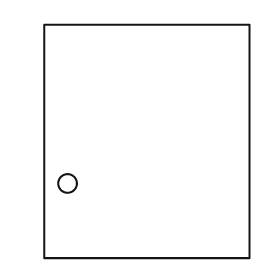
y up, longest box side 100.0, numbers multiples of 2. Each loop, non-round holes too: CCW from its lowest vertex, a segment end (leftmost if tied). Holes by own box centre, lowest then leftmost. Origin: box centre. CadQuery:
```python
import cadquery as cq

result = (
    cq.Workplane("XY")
    .moveTo(-44.0, -50.0)
    .lineTo(44.0, -50.0)
    .lineTo(44.0, 50.0)
    .lineTo(-44.0, 50.0)
    .close()
    .moveTo(-34.0, -18.0)
    .circle(4.0)
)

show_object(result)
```